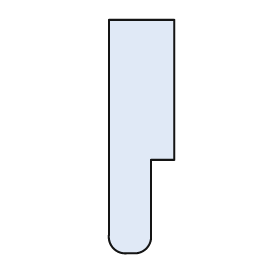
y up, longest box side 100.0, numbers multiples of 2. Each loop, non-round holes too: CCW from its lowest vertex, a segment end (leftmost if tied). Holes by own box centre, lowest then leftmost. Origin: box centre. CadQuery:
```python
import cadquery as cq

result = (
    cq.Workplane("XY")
    .moveTo(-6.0, -50.0)
    .lineTo(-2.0, -50.0)
    .threePointArc((2.0, -48.0), (4.0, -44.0))
    .lineTo(4.0, -10.0)
    .lineTo(14.0, -10.0)
    .lineTo(14.0, 50.0)
    .lineTo(-14.0, 50.0)
    .lineTo(-14.0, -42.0)
    .threePointArc((-12.0, -48.0), (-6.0, -50.0))
    .close()
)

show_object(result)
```